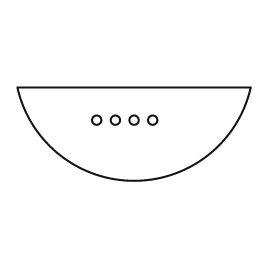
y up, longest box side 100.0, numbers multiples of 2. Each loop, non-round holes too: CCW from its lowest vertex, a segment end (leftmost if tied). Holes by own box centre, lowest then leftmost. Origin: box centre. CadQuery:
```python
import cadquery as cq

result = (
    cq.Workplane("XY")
    .moveTo(-50.0, 20.0)
    .threePointArc((0.0, -20.0), (50.0, 20.0))
    .close()
    .moveTo(-16.0, 6.0)
    .circle(2.0)
    .moveTo(-8.0, 6.0)
    .circle(2.0)
    .moveTo(0.0, 6.0)
    .circle(2.0)
    .moveTo(8.0, 6.0)
    .circle(2.0)
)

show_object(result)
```